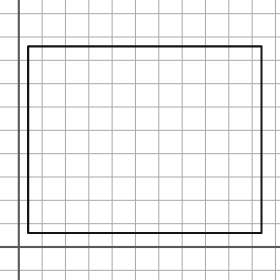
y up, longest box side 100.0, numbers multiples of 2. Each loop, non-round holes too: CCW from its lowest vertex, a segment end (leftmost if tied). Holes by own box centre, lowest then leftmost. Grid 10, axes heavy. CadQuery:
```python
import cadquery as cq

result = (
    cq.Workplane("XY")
    .moveTo(4.0, 6.0)
    .lineTo(104.0, 6.0)
    .lineTo(104.0, 86.0)
    .lineTo(4.0, 86.0)
    .close()
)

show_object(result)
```